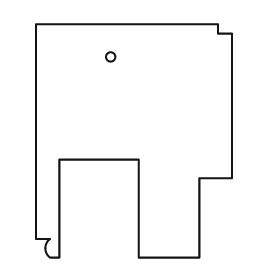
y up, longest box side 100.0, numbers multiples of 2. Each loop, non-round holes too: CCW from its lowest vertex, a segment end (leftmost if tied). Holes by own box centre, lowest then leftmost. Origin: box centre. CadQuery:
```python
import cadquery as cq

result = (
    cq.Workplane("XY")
    .moveTo(-36.0, -50.0)
    .lineTo(-32.0, -50.0)
    .lineTo(-32.0, -8.0)
    .lineTo(2.0, -8.0)
    .lineTo(2.0, -50.0)
    .lineTo(28.0, -50.0)
    .lineTo(28.0, -16.0)
    .lineTo(42.0, -16.0)
    .lineTo(42.0, 46.0)
    .lineTo(36.0, 46.0)
    .lineTo(36.0, 50.0)
    .lineTo(-42.0, 50.0)
    .lineTo(-42.0, -42.0)
    .lineTo(-36.0, -42.0)
    .threePointArc((-38.0, -46.0), (-36.0, -50.0))
    .close()
    .moveTo(-10.0, 36.0)
    .circle(2.0)
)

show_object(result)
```